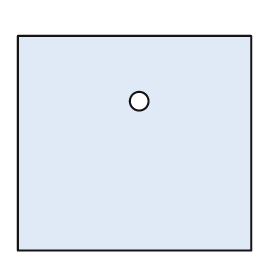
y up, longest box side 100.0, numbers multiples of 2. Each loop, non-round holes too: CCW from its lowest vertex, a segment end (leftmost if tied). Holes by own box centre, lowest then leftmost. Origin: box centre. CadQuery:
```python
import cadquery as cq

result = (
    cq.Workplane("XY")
    .moveTo(-50.0, -46.0)
    .lineTo(50.0, -46.0)
    .lineTo(50.0, 46.0)
    .lineTo(-50.0, 46.0)
    .close()
    .moveTo(2.0, 18.0)
    .circle(4.0)
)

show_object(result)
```